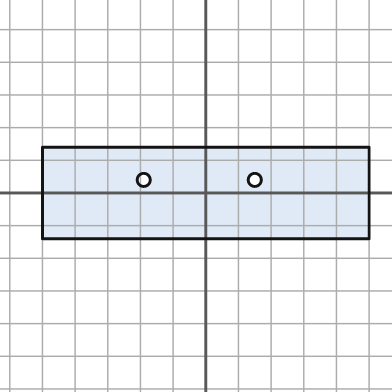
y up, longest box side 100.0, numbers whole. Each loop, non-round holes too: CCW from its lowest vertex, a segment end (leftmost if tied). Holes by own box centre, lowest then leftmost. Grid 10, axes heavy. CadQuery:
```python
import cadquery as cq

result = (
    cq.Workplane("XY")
    .moveTo(-50.0, -14.0)
    .lineTo(50.0, -14.0)
    .lineTo(50.0, 14.0)
    .lineTo(-50.0, 14.0)
    .close()
    .moveTo(-19.0, 4.0)
    .circle(2.0)
    .moveTo(15.0, 4.0)
    .circle(2.0)
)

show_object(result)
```